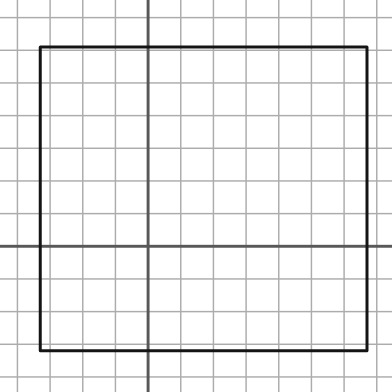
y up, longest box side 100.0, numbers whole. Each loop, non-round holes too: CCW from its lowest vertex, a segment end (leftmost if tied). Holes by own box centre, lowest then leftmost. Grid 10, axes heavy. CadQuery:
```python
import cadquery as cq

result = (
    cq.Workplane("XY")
    .moveTo(-33.0, -32.0)
    .lineTo(67.0, -32.0)
    .lineTo(67.0, 61.0)
    .lineTo(-33.0, 61.0)
    .close()
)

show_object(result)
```